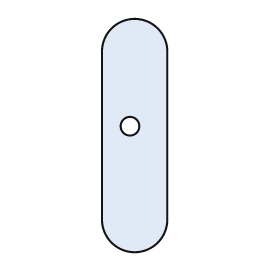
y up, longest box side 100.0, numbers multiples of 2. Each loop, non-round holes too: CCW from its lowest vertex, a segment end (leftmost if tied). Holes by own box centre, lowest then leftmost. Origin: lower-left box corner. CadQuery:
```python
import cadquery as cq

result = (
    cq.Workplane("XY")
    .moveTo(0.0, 14.0)
    .threePointArc((14.0, 0.0), (28.0, 14.0))
    .lineTo(28.0, 86.0)
    .threePointArc((14.0, 100.0), (0.0, 86.0))
    .close()
    .moveTo(12.0, 54.0)
    .circle(4.0)
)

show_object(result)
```